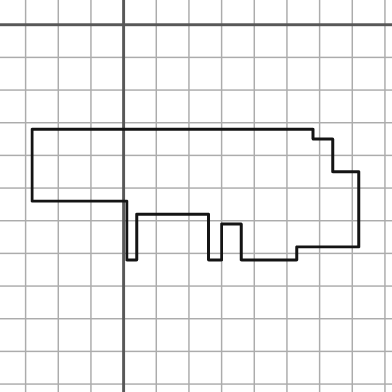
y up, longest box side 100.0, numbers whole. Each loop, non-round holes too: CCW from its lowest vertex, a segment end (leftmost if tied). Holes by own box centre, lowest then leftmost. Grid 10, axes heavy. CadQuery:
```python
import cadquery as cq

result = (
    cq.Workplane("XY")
    .moveTo(1.0, -72.0)
    .lineTo(4.0, -72.0)
    .lineTo(4.0, -58.0)
    .lineTo(26.0, -58.0)
    .lineTo(26.0, -72.0)
    .lineTo(30.0, -72.0)
    .lineTo(30.0, -61.0)
    .lineTo(36.0, -61.0)
    .lineTo(36.0, -72.0)
    .lineTo(53.0, -72.0)
    .lineTo(53.0, -68.0)
    .lineTo(72.0, -68.0)
    .lineTo(72.0, -45.0)
    .lineTo(64.0, -45.0)
    .lineTo(64.0, -35.0)
    .lineTo(58.0, -35.0)
    .lineTo(58.0, -32.0)
    .lineTo(-28.0, -32.0)
    .lineTo(-28.0, -54.0)
    .lineTo(1.0, -54.0)
    .close()
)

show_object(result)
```